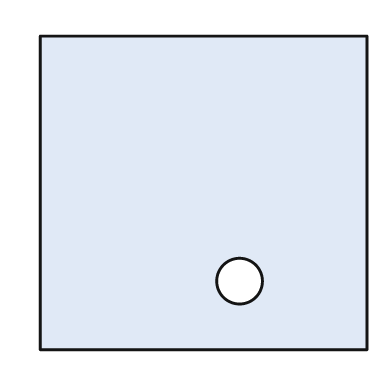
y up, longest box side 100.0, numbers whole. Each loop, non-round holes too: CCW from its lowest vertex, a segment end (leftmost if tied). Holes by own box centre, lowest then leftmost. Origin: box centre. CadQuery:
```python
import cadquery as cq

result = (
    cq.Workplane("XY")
    .moveTo(-50.0, -48.0)
    .lineTo(50.0, -48.0)
    .lineTo(50.0, 48.0)
    .lineTo(-50.0, 48.0)
    .close()
    .moveTo(11.0, -27.0)
    .circle(7.0)
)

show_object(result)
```